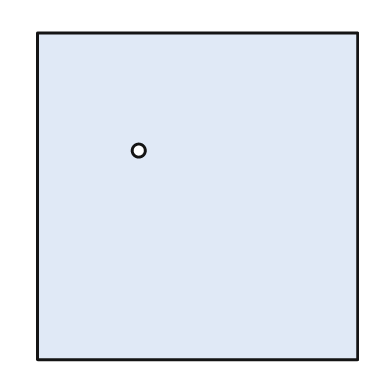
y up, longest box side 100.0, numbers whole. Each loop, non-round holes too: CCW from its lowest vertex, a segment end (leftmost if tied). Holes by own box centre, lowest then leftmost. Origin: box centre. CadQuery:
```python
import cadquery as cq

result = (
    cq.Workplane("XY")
    .moveTo(-49.0, -50.0)
    .lineTo(49.0, -50.0)
    .lineTo(49.0, 50.0)
    .lineTo(-49.0, 50.0)
    .close()
    .moveTo(-18.0, 14.0)
    .circle(2.0)
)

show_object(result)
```